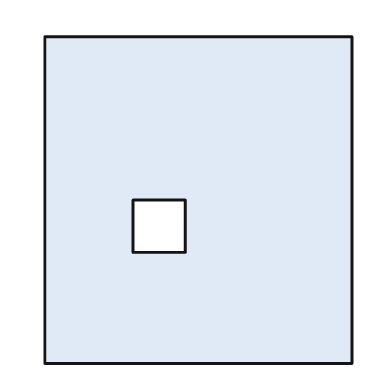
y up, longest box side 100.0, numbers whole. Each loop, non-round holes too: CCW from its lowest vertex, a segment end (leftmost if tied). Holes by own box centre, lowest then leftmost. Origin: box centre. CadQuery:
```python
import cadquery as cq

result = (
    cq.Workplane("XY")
    .moveTo(-47.0, -50.0)
    .lineTo(47.0, -50.0)
    .lineTo(47.0, 50.0)
    .lineTo(-47.0, 50.0)
    .close()
    .moveTo(-20.0, -16.0)
    .lineTo(-4.0, -16.0)
    .lineTo(-4.0, 0.0)
    .lineTo(-20.0, 0.0)
    .close()
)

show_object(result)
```